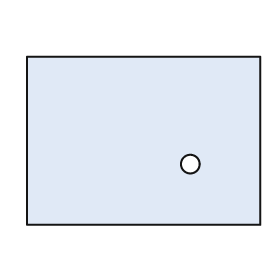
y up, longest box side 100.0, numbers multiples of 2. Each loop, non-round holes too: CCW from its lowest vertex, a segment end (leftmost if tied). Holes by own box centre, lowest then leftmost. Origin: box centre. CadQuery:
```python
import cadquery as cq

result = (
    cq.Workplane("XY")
    .moveTo(-50.0, -36.0)
    .lineTo(50.0, -36.0)
    .lineTo(50.0, 36.0)
    .lineTo(-50.0, 36.0)
    .close()
    .moveTo(20.0, -10.0)
    .circle(4.0)
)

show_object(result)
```